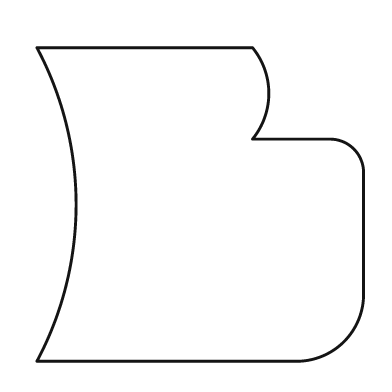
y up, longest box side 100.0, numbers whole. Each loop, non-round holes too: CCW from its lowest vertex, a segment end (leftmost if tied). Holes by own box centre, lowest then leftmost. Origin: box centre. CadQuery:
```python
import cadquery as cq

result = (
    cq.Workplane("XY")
    .moveTo(-50.0, -48.0)
    .lineTo(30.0, -48.0)
    .threePointArc((44.0, -42.0), (50.0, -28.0))
    .lineTo(50.0, 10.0)
    .threePointArc((47.0, 17.0), (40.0, 20.0))
    .lineTo(16.0, 20.0)
    .threePointArc((21.0, 34.0), (16.0, 48.0))
    .lineTo(-50.0, 48.0)
    .threePointArc((-38.0, 0.0), (-50.0, -48.0))
    .close()
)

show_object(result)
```